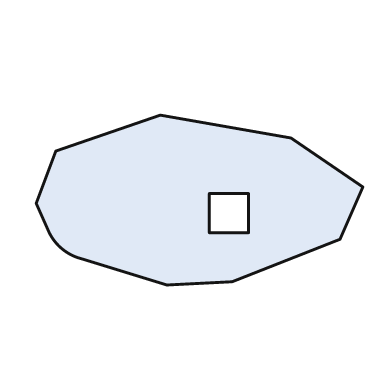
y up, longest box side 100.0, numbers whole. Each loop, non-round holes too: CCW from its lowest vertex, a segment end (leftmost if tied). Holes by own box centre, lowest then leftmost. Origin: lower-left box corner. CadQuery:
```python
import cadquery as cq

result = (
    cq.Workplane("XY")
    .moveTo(40.0, 0.0)
    .lineTo(60.0, 1.0)
    .lineTo(93.0, 14.0)
    .lineTo(100.0, 30.0)
    .lineTo(78.0, 45.0)
    .lineTo(38.0, 52.0)
    .lineTo(6.0, 41.0)
    .lineTo(0.0, 25.0)
    .lineTo(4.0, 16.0)
    .threePointArc((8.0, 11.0), (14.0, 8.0))
    .close()
    .moveTo(53.0, 16.0)
    .lineTo(65.0, 16.0)
    .lineTo(65.0, 28.0)
    .lineTo(53.0, 28.0)
    .close()
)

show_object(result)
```